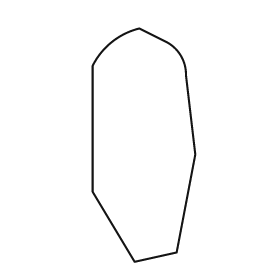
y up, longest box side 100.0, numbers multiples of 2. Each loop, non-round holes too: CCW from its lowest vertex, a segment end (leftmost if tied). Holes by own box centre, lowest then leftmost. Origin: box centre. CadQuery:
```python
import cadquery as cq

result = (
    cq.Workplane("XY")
    .moveTo(-4.0, -50.0)
    .lineTo(14.0, -46.0)
    .lineTo(22.0, -4.0)
    .lineTo(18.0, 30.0)
    .threePointArc((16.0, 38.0), (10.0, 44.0))
    .lineTo(-2.0, 50.0)
    .threePointArc((-14.0, 44.0), (-22.0, 34.0))
    .lineTo(-22.0, -20.0)
    .close()
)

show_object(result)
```